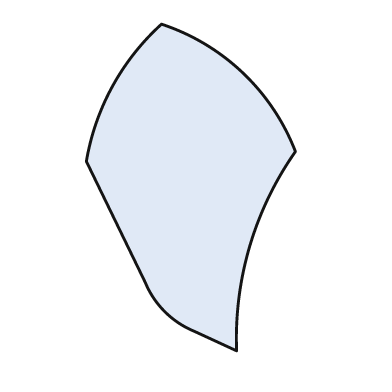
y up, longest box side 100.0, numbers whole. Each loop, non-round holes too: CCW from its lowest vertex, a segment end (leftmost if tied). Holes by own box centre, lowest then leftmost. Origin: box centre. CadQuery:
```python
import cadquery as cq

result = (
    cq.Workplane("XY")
    .moveTo(14.0, -50.0)
    .threePointArc((18.0, -18.0), (32.0, 11.0))
    .threePointArc((16.0, 35.0), (-9.0, 50.0))
    .threePointArc((-24.0, 31.0), (-32.0, 8.0))
    .lineTo(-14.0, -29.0)
    .threePointArc((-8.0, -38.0), (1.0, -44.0))
    .close()
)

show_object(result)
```